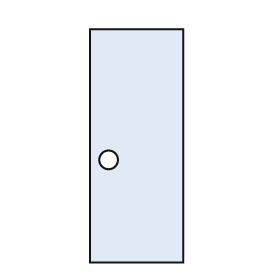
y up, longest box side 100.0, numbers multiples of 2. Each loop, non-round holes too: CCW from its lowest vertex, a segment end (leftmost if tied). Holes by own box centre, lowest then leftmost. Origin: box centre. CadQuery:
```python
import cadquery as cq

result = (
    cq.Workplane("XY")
    .moveTo(-20.0, -50.0)
    .lineTo(20.0, -50.0)
    .lineTo(20.0, 50.0)
    .lineTo(-20.0, 50.0)
    .close()
    .moveTo(-12.0, -6.0)
    .circle(4.0)
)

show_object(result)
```